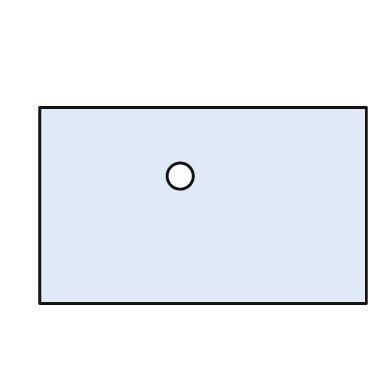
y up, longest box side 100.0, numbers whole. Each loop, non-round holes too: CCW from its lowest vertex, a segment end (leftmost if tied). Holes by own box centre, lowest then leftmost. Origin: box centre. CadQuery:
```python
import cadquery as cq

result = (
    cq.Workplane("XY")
    .moveTo(-50.0, -30.0)
    .lineTo(50.0, -30.0)
    .lineTo(50.0, 30.0)
    .lineTo(-50.0, 30.0)
    .close()
    .moveTo(-7.0, 9.0)
    .circle(4.0)
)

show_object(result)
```